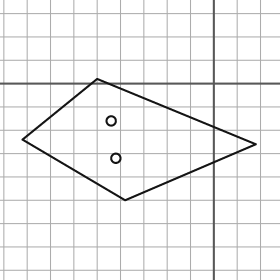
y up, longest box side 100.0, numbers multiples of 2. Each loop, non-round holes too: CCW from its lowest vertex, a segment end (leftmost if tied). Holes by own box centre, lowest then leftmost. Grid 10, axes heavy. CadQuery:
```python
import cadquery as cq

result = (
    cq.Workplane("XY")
    .moveTo(-38.0, -50.0)
    .lineTo(18.0, -26.0)
    .lineTo(-50.0, 2.0)
    .lineTo(-82.0, -24.0)
    .close()
    .moveTo(-42.0, -32.0)
    .circle(2.0)
    .moveTo(-44.0, -16.0)
    .circle(2.0)
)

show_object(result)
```